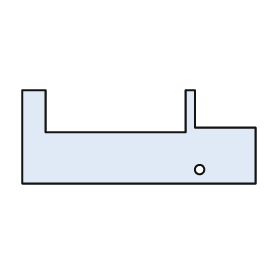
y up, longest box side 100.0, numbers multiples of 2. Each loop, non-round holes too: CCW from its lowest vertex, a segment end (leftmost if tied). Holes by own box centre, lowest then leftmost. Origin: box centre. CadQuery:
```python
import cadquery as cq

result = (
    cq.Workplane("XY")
    .moveTo(-50.0, -20.0)
    .lineTo(50.0, -20.0)
    .lineTo(50.0, 4.0)
    .lineTo(24.0, 4.0)
    .lineTo(24.0, 20.0)
    .lineTo(20.0, 20.0)
    .lineTo(20.0, 2.0)
    .lineTo(-40.0, 2.0)
    .lineTo(-40.0, 20.0)
    .lineTo(-50.0, 20.0)
    .close()
    .moveTo(26.0, -14.0)
    .circle(2.0)
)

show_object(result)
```